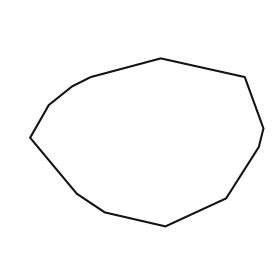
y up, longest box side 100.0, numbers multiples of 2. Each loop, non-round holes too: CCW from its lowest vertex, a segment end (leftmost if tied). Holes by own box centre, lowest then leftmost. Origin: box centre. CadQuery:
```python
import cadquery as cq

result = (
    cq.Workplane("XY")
    .moveTo(8.0, -36.0)
    .lineTo(34.0, -24.0)
    .lineTo(48.0, -2.0)
    .lineTo(50.0, 6.0)
    .lineTo(42.0, 28.0)
    .lineTo(6.0, 36.0)
    .lineTo(-24.0, 28.0)
    .lineTo(-32.0, 24.0)
    .lineTo(-42.0, 16.0)
    .lineTo(-50.0, 2.0)
    .lineTo(-30.0, -22.0)
    .lineTo(-18.0, -30.0)
    .close()
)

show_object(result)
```